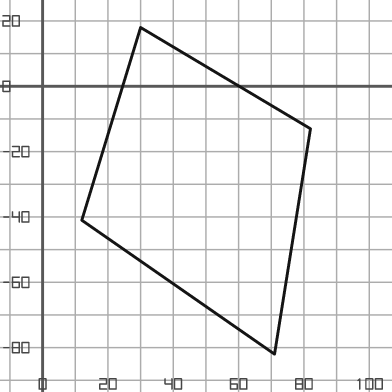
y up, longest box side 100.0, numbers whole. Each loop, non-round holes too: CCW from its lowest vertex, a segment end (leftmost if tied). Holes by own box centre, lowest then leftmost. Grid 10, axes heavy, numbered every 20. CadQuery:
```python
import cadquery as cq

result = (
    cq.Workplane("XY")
    .moveTo(71.0, -82.0)
    .lineTo(82.0, -13.0)
    .lineTo(30.0, 18.0)
    .lineTo(12.0, -41.0)
    .close()
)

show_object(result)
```